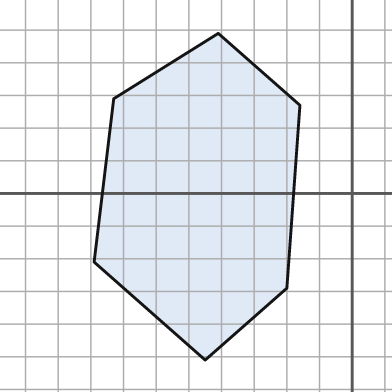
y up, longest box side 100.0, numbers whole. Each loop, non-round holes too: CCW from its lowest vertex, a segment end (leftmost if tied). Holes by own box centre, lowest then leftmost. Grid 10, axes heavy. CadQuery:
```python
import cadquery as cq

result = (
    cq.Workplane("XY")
    .moveTo(-45.0, -51.0)
    .lineTo(-20.0, -29.0)
    .lineTo(-16.0, 27.0)
    .lineTo(-41.0, 49.0)
    .lineTo(-73.0, 29.0)
    .lineTo(-79.0, -21.0)
    .close()
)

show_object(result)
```